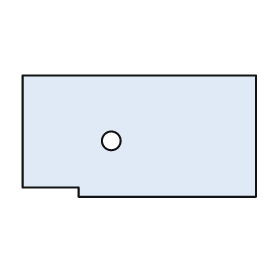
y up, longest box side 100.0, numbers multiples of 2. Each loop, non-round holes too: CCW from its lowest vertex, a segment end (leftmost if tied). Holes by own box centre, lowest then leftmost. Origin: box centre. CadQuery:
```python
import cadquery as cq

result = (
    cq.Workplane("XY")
    .moveTo(-26.0, -26.0)
    .lineTo(50.0, -26.0)
    .lineTo(50.0, 26.0)
    .lineTo(-50.0, 26.0)
    .lineTo(-50.0, -22.0)
    .lineTo(-26.0, -22.0)
    .close()
    .moveTo(-12.0, -2.0)
    .circle(4.0)
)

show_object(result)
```